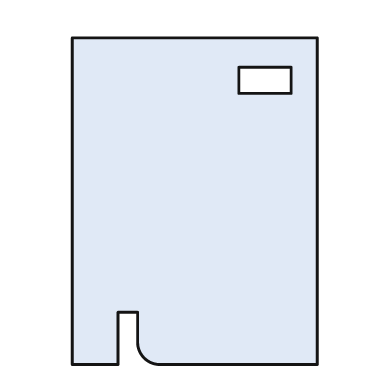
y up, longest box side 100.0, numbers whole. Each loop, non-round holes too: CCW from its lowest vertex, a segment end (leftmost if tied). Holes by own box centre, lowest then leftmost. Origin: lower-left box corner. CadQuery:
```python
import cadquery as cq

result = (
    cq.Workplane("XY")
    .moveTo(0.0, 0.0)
    .lineTo(14.0, 0.0)
    .lineTo(14.0, 16.0)
    .lineTo(20.0, 16.0)
    .lineTo(20.0, 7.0)
    .threePointArc((22.0, 2.0), (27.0, 0.0))
    .lineTo(75.0, 0.0)
    .lineTo(75.0, 100.0)
    .lineTo(0.0, 100.0)
    .close()
    .moveTo(51.0, 83.0)
    .lineTo(67.0, 83.0)
    .lineTo(67.0, 91.0)
    .lineTo(51.0, 91.0)
    .close()
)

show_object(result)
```